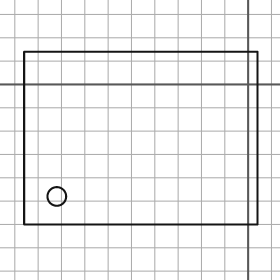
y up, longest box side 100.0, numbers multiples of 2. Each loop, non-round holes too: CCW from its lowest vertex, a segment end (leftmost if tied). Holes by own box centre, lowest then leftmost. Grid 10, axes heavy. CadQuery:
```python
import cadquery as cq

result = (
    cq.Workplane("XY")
    .moveTo(-96.0, -60.0)
    .lineTo(4.0, -60.0)
    .lineTo(4.0, 14.0)
    .lineTo(-96.0, 14.0)
    .close()
    .moveTo(-82.0, -48.0)
    .circle(4.0)
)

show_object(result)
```